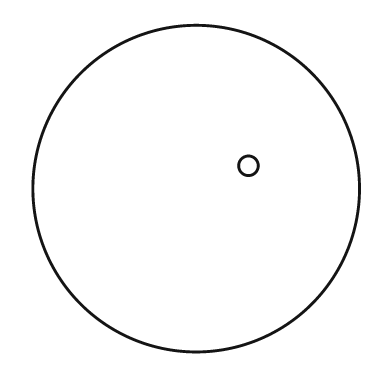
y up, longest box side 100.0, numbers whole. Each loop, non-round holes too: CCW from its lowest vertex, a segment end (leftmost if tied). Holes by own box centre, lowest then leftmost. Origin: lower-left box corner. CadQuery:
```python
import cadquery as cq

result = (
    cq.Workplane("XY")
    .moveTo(50.0, 50.0)
    .circle(50.0)
    .moveTo(66.0, 57.0)
    .circle(3.0)
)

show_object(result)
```